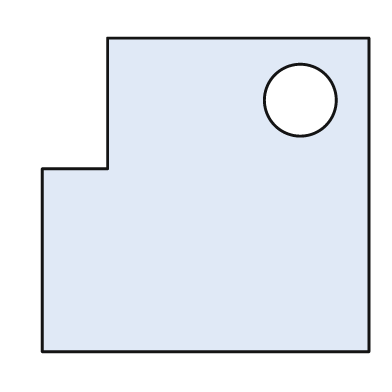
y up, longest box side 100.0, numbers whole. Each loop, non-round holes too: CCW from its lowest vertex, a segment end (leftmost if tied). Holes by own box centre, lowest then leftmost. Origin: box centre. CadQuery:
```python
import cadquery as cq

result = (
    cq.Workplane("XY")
    .moveTo(-50.0, -48.0)
    .lineTo(50.0, -48.0)
    .lineTo(50.0, 48.0)
    .lineTo(-30.0, 48.0)
    .lineTo(-30.0, 8.0)
    .lineTo(-50.0, 8.0)
    .close()
    .moveTo(29.0, 29.0)
    .circle(11.0)
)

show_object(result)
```